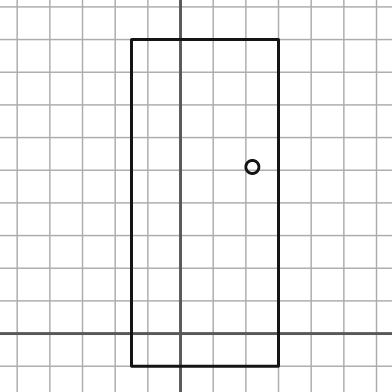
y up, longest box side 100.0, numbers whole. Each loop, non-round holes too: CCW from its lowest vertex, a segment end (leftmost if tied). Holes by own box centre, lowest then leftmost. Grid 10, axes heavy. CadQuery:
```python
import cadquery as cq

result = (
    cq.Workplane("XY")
    .moveTo(-15.0, -10.0)
    .lineTo(30.0, -10.0)
    .lineTo(30.0, 90.0)
    .lineTo(-15.0, 90.0)
    .close()
    .moveTo(22.0, 51.0)
    .circle(2.0)
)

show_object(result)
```